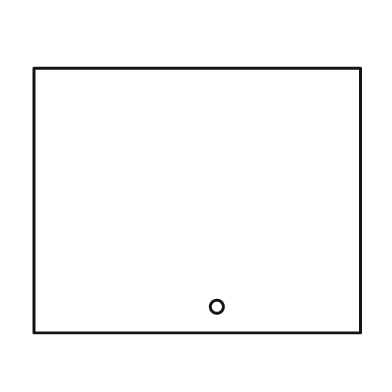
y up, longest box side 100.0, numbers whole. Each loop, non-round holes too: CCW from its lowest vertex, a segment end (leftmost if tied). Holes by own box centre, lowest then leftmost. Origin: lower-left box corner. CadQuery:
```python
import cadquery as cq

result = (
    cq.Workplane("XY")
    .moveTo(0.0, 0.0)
    .lineTo(100.0, 0.0)
    .lineTo(100.0, 81.0)
    .lineTo(0.0, 81.0)
    .close()
    .moveTo(56.0, 8.0)
    .circle(2.0)
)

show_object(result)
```